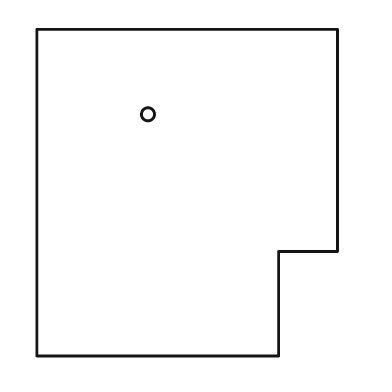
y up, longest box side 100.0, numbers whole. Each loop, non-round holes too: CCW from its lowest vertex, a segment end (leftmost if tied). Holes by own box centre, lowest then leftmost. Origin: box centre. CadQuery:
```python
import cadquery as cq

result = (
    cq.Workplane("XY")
    .moveTo(-46.0, -50.0)
    .lineTo(28.0, -50.0)
    .lineTo(28.0, -18.0)
    .lineTo(46.0, -18.0)
    .lineTo(46.0, 50.0)
    .lineTo(-46.0, 50.0)
    .close()
    .moveTo(-12.0, 24.0)
    .circle(2.0)
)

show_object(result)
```